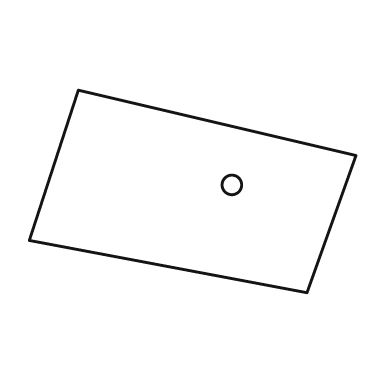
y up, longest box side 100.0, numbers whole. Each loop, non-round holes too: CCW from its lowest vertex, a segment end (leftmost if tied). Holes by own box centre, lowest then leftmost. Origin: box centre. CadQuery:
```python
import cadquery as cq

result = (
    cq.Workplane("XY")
    .moveTo(35.0, -31.0)
    .lineTo(50.0, 11.0)
    .lineTo(-35.0, 31.0)
    .lineTo(-50.0, -15.0)
    .close()
    .moveTo(12.0, 2.0)
    .circle(3.0)
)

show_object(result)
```